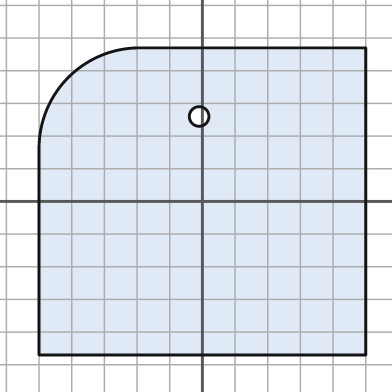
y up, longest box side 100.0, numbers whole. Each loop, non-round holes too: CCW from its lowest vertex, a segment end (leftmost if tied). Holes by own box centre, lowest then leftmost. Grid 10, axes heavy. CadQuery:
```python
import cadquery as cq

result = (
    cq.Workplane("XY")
    .moveTo(-50.0, -47.0)
    .lineTo(50.0, -47.0)
    .lineTo(50.0, 47.0)
    .lineTo(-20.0, 47.0)
    .threePointArc((-41.0, 38.0), (-50.0, 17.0))
    .close()
    .moveTo(-1.0, 26.0)
    .circle(3.0)
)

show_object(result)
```